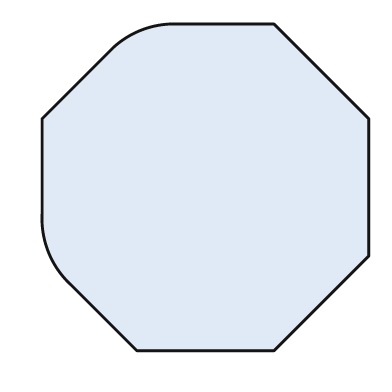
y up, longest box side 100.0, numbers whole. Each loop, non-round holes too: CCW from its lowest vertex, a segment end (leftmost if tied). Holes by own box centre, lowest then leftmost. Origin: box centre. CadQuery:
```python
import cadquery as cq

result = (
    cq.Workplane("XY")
    .moveTo(-21.0, -50.0)
    .lineTo(21.0, -50.0)
    .lineTo(50.0, -21.0)
    .lineTo(50.0, 21.0)
    .lineTo(21.0, 50.0)
    .lineTo(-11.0, 50.0)
    .threePointArc((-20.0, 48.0), (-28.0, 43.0))
    .lineTo(-50.0, 21.0)
    .lineTo(-50.0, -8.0)
    .threePointArc((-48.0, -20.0), (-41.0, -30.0))
    .close()
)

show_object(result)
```